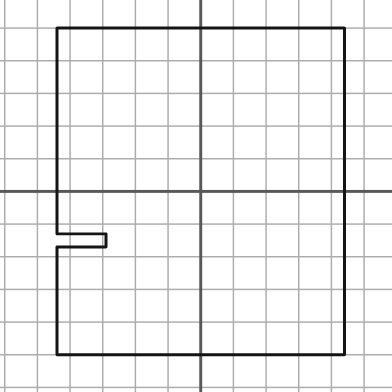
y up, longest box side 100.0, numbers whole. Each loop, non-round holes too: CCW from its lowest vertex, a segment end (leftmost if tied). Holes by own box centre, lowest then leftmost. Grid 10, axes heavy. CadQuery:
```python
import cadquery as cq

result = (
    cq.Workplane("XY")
    .moveTo(-44.0, -50.0)
    .lineTo(44.0, -50.0)
    .lineTo(44.0, 50.0)
    .lineTo(-44.0, 50.0)
    .lineTo(-44.0, -13.0)
    .lineTo(-29.0, -13.0)
    .lineTo(-29.0, -17.0)
    .lineTo(-44.0, -17.0)
    .close()
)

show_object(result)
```